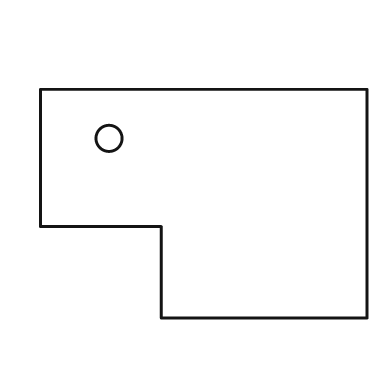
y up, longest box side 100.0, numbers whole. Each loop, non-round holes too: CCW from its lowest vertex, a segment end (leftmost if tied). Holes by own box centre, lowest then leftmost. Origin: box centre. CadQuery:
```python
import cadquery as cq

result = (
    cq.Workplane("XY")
    .moveTo(-13.0, -35.0)
    .lineTo(50.0, -35.0)
    .lineTo(50.0, 35.0)
    .lineTo(-50.0, 35.0)
    .lineTo(-50.0, -7.0)
    .lineTo(-13.0, -7.0)
    .close()
    .moveTo(-29.0, 20.0)
    .circle(4.0)
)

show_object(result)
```